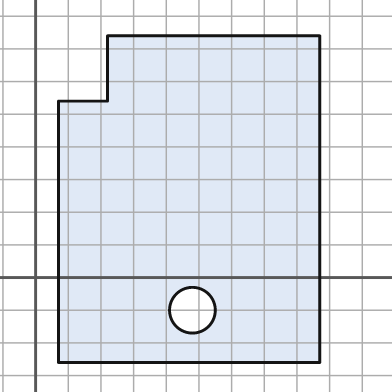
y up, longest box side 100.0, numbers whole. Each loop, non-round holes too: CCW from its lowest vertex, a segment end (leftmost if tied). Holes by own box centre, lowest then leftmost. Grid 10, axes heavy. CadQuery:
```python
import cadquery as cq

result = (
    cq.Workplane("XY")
    .moveTo(7.0, -26.0)
    .lineTo(87.0, -26.0)
    .lineTo(87.0, 74.0)
    .lineTo(22.0, 74.0)
    .lineTo(22.0, 54.0)
    .lineTo(7.0, 54.0)
    .close()
    .moveTo(48.0, -10.0)
    .circle(7.0)
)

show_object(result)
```